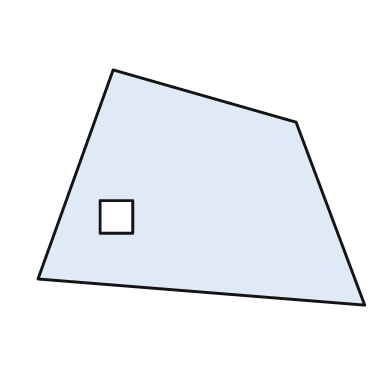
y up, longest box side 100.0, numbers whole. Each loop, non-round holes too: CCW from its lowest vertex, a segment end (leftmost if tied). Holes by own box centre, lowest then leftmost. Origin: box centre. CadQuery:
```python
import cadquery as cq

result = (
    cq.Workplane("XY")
    .moveTo(50.0, -36.0)
    .lineTo(29.0, 20.0)
    .lineTo(-27.0, 36.0)
    .lineTo(-50.0, -28.0)
    .close()
    .moveTo(-31.0, -14.0)
    .lineTo(-21.0, -14.0)
    .lineTo(-21.0, -4.0)
    .lineTo(-31.0, -4.0)
    .close()
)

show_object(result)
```